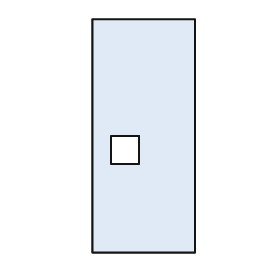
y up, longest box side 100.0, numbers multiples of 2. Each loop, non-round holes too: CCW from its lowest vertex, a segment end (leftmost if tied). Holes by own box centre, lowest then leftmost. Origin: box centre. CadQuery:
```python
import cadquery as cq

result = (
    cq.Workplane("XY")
    .moveTo(-22.0, -50.0)
    .lineTo(22.0, -50.0)
    .lineTo(22.0, 50.0)
    .lineTo(-22.0, 50.0)
    .close()
    .moveTo(-14.0, -12.0)
    .lineTo(-2.0, -12.0)
    .lineTo(-2.0, 0.0)
    .lineTo(-14.0, 0.0)
    .close()
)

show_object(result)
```